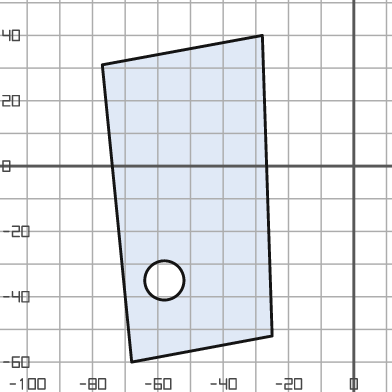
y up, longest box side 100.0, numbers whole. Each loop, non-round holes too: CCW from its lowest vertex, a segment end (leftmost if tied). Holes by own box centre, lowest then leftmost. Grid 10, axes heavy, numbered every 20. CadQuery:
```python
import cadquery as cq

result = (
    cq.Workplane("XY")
    .moveTo(-68.0, -60.0)
    .lineTo(-25.0, -52.0)
    .lineTo(-28.0, 40.0)
    .lineTo(-77.0, 31.0)
    .close()
    .moveTo(-58.0, -35.0)
    .circle(6.0)
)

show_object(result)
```